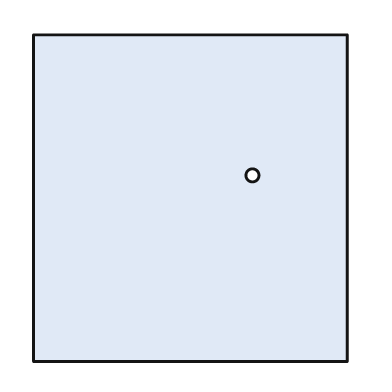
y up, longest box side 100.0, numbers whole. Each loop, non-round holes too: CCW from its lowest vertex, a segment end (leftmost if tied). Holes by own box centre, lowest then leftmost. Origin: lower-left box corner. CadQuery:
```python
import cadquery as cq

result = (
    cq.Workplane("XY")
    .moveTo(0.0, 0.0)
    .lineTo(96.0, 0.0)
    .lineTo(96.0, 100.0)
    .lineTo(0.0, 100.0)
    .close()
    .moveTo(67.0, 57.0)
    .circle(2.0)
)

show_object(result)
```